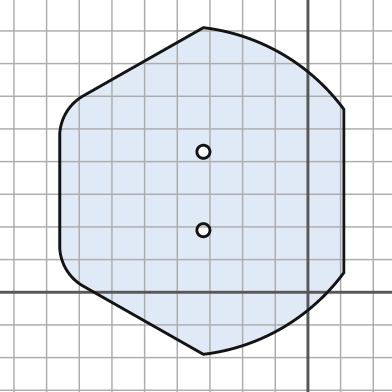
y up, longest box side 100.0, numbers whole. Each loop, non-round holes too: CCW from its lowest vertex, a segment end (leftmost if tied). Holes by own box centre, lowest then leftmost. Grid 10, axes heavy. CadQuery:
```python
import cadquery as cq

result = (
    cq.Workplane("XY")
    .moveTo(-32.0, -19.0)
    .threePointArc((-8.0, -11.0), (11.0, 6.0))
    .lineTo(11.0, 56.0)
    .threePointArc((-8.0, 73.0), (-32.0, 81.0))
    .lineTo(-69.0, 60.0)
    .threePointArc((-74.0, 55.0), (-76.0, 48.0))
    .lineTo(-76.0, 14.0)
    .threePointArc((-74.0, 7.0), (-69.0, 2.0))
    .close()
    .moveTo(-32.0, 19.0)
    .circle(2.0)
    .moveTo(-32.0, 43.0)
    .circle(2.0)
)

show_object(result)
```